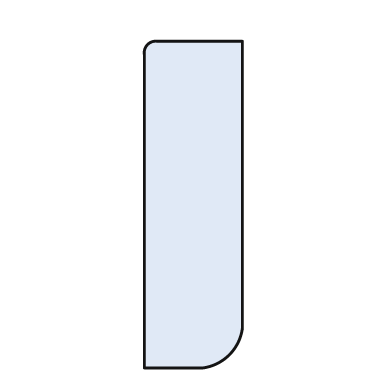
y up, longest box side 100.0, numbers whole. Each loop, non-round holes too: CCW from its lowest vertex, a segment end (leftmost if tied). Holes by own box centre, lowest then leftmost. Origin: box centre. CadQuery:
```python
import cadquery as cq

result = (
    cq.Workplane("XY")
    .moveTo(-15.0, -50.0)
    .lineTo(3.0, -50.0)
    .threePointArc((11.0, -46.0), (15.0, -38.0))
    .lineTo(15.0, 50.0)
    .lineTo(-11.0, 50.0)
    .threePointArc((-14.0, 49.0), (-15.0, 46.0))
    .close()
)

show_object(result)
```